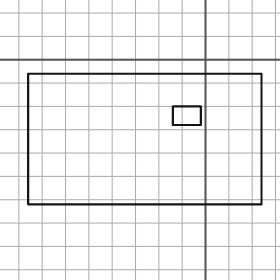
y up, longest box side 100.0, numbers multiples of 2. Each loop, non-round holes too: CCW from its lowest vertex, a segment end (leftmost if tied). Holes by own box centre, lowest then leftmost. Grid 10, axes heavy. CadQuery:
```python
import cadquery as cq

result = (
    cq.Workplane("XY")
    .moveTo(-76.0, -62.0)
    .lineTo(24.0, -62.0)
    .lineTo(24.0, -6.0)
    .lineTo(-76.0, -6.0)
    .close()
    .moveTo(-14.0, -28.0)
    .lineTo(-2.0, -28.0)
    .lineTo(-2.0, -20.0)
    .lineTo(-14.0, -20.0)
    .close()
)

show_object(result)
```